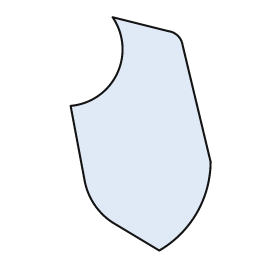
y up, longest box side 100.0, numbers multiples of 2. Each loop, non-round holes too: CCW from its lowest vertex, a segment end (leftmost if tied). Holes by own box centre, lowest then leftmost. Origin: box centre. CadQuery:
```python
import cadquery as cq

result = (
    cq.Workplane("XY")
    .moveTo(8.0, -50.0)
    .threePointArc((24.0, -34.0), (30.0, -12.0))
    .lineTo(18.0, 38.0)
    .threePointArc((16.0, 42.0), (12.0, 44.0))
    .lineTo(-12.0, 50.0)
    .threePointArc((-10.0, 26.0), (-30.0, 12.0))
    .lineTo(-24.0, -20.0)
    .threePointArc((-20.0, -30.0), (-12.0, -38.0))
    .close()
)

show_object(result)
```